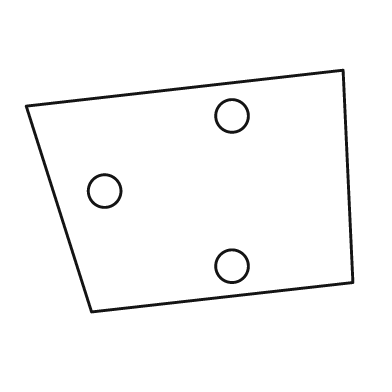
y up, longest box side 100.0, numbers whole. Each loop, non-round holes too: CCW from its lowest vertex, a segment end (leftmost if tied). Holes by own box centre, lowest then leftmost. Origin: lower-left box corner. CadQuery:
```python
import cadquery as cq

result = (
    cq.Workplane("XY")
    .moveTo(20.0, 0.0)
    .lineTo(100.0, 9.0)
    .lineTo(97.0, 74.0)
    .lineTo(0.0, 63.0)
    .close()
    .moveTo(63.0, 14.0)
    .circle(5.0)
    .moveTo(24.0, 37.0)
    .circle(5.0)
    .moveTo(63.0, 60.0)
    .circle(5.0)
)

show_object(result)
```